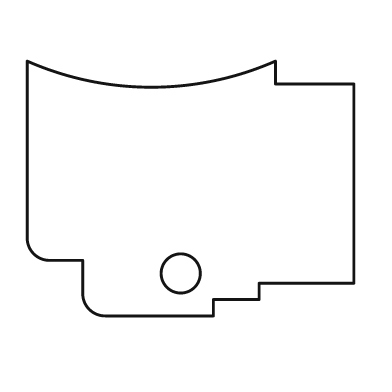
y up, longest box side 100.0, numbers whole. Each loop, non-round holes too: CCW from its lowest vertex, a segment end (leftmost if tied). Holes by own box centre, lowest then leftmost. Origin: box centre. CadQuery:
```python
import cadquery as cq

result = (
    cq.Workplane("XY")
    .moveTo(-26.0, -39.0)
    .lineTo(7.0, -39.0)
    .lineTo(7.0, -34.0)
    .lineTo(21.0, -34.0)
    .lineTo(21.0, -29.0)
    .lineTo(50.0, -29.0)
    .lineTo(50.0, 32.0)
    .lineTo(26.0, 32.0)
    .lineTo(26.0, 39.0)
    .threePointArc((-12.0, 31.0), (-50.0, 39.0))
    .lineTo(-50.0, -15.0)
    .threePointArc((-48.0, -20.0), (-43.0, -22.0))
    .lineTo(-33.0, -22.0)
    .lineTo(-33.0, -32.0)
    .threePointArc((-31.0, -37.0), (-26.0, -39.0))
    .close()
    .moveTo(-3.0, -26.0)
    .circle(6.0)
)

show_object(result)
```